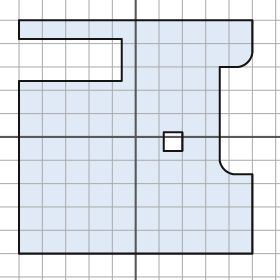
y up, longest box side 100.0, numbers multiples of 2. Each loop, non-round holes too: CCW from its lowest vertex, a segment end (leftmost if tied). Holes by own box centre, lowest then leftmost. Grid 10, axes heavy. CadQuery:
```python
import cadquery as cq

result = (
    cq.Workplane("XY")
    .moveTo(-50.0, -50.0)
    .lineTo(50.0, -50.0)
    .lineTo(50.0, -16.0)
    .lineTo(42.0, -16.0)
    .threePointArc((38.0, -14.0), (36.0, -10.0))
    .lineTo(36.0, 30.0)
    .lineTo(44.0, 30.0)
    .threePointArc((48.0, 32.0), (50.0, 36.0))
    .lineTo(50.0, 50.0)
    .lineTo(-50.0, 50.0)
    .lineTo(-50.0, 42.0)
    .lineTo(-6.0, 42.0)
    .lineTo(-6.0, 24.0)
    .lineTo(-50.0, 24.0)
    .close()
    .moveTo(12.0, -6.0)
    .lineTo(20.0, -6.0)
    .lineTo(20.0, 2.0)
    .lineTo(12.0, 2.0)
    .close()
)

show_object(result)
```